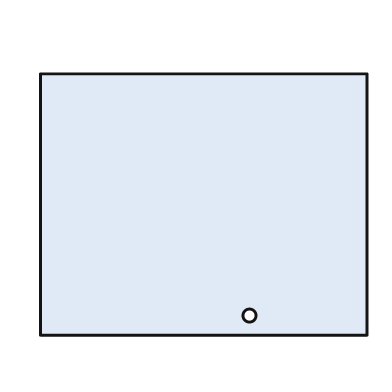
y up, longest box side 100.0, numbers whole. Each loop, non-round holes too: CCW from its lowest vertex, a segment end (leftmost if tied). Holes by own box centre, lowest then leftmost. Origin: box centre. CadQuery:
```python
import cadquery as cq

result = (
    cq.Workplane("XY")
    .moveTo(-50.0, -40.0)
    .lineTo(50.0, -40.0)
    .lineTo(50.0, 40.0)
    .lineTo(-50.0, 40.0)
    .close()
    .moveTo(14.0, -34.0)
    .circle(2.0)
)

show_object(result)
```